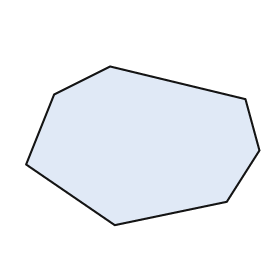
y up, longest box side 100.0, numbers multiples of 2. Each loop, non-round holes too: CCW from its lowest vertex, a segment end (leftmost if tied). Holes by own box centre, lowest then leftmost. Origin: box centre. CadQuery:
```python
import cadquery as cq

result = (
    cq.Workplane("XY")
    .moveTo(-12.0, -34.0)
    .lineTo(36.0, -24.0)
    .lineTo(50.0, -2.0)
    .lineTo(44.0, 20.0)
    .lineTo(-14.0, 34.0)
    .lineTo(-38.0, 22.0)
    .lineTo(-50.0, -8.0)
    .close()
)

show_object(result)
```